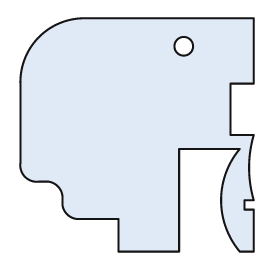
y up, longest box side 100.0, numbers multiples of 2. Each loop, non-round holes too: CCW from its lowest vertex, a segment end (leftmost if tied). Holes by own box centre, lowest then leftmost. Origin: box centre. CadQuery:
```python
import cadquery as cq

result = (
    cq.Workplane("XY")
    .moveTo(-8.0, -50.0)
    .lineTo(18.0, -50.0)
    .lineTo(18.0, -6.0)
    .lineTo(44.0, -6.0)
    .threePointArc((36.0, -28.0), (44.0, -50.0))
    .lineTo(50.0, -50.0)
    .lineTo(50.0, -32.0)
    .lineTo(46.0, -32.0)
    .lineTo(46.0, -28.0)
    .lineTo(50.0, -28.0)
    .threePointArc((48.0, -14.0), (50.0, 0.0))
    .lineTo(40.0, 0.0)
    .lineTo(40.0, 22.0)
    .lineTo(50.0, 22.0)
    .lineTo(50.0, 50.0)
    .lineTo(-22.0, 50.0)
    .threePointArc((-42.0, 42.0), (-50.0, 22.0))
    .lineTo(-50.0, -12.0)
    .threePointArc((-48.0, -18.0), (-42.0, -20.0))
    .lineTo(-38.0, -20.0)
    .threePointArc((-34.0, -22.0), (-32.0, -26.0))
    .lineTo(-32.0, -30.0)
    .threePointArc((-30.0, -34.0), (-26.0, -36.0))
    .lineTo(-8.0, -36.0)
    .close()
    .moveTo(20.0, 38.0)
    .circle(4.0)
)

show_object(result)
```